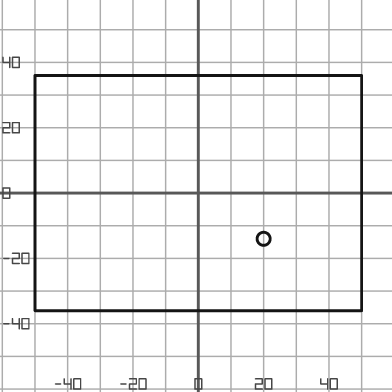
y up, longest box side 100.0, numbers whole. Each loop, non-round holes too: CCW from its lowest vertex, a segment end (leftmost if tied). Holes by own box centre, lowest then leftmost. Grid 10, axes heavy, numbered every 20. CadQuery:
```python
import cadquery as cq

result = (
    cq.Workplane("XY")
    .moveTo(-50.0, -36.0)
    .lineTo(50.0, -36.0)
    .lineTo(50.0, 36.0)
    .lineTo(-50.0, 36.0)
    .close()
    .moveTo(20.0, -14.0)
    .circle(2.0)
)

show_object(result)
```